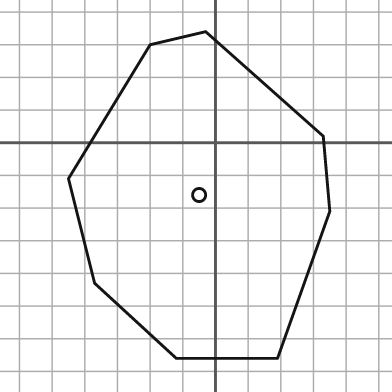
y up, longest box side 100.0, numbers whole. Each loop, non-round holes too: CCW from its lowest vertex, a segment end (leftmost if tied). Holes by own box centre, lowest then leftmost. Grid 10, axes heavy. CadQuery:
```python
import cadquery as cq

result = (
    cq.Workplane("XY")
    .moveTo(-12.0, -66.0)
    .lineTo(19.0, -66.0)
    .lineTo(35.0, -21.0)
    .lineTo(33.0, 2.0)
    .lineTo(-3.0, 34.0)
    .lineTo(-20.0, 30.0)
    .lineTo(-45.0, -11.0)
    .lineTo(-37.0, -43.0)
    .close()
    .moveTo(-5.0, -16.0)
    .circle(2.0)
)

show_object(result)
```